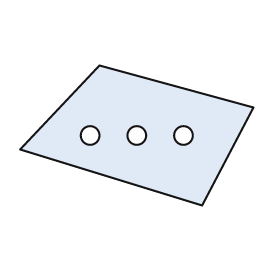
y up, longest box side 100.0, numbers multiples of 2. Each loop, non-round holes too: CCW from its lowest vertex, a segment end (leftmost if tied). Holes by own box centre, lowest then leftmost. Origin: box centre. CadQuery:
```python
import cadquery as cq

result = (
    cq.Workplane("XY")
    .moveTo(28.0, -30.0)
    .lineTo(50.0, 12.0)
    .lineTo(-16.0, 30.0)
    .lineTo(-50.0, -6.0)
    .close()
    .moveTo(-20.0, 0.0)
    .circle(4.0)
    .moveTo(0.0, 0.0)
    .circle(4.0)
    .moveTo(20.0, 0.0)
    .circle(4.0)
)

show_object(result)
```